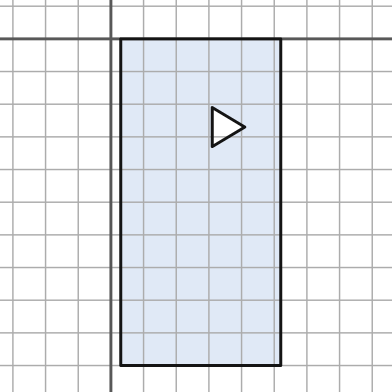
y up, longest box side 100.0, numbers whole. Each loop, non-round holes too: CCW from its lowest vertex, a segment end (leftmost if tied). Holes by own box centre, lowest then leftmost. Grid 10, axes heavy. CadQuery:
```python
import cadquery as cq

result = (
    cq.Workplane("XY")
    .moveTo(3.0, -100.0)
    .lineTo(52.0, -100.0)
    .lineTo(52.0, 0.0)
    .lineTo(3.0, 0.0)
    .close()
    .moveTo(31.0, -33.0)
    .lineTo(41.0, -27.0)
    .lineTo(31.0, -21.0)
    .close()
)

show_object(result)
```